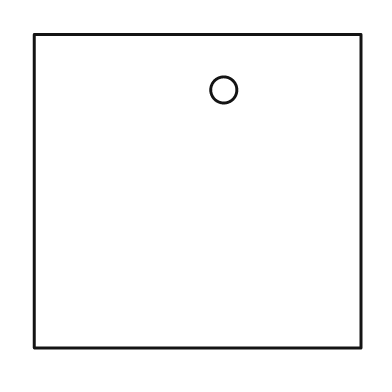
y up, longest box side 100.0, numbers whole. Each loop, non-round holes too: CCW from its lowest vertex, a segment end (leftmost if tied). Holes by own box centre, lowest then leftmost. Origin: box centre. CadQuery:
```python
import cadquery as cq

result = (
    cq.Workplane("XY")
    .moveTo(-50.0, -48.0)
    .lineTo(50.0, -48.0)
    .lineTo(50.0, 48.0)
    .lineTo(-50.0, 48.0)
    .close()
    .moveTo(8.0, 31.0)
    .circle(4.0)
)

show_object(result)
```